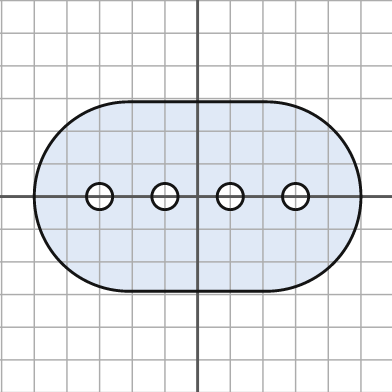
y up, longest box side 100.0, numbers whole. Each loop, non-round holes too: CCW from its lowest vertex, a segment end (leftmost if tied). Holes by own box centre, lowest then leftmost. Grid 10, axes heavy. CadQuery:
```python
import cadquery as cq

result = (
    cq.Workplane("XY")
    .moveTo(-21.0, -29.0)
    .lineTo(21.0, -29.0)
    .threePointArc((50.0, 0.0), (21.0, 29.0))
    .lineTo(-21.0, 29.0)
    .threePointArc((-50.0, 0.0), (-21.0, -29.0))
    .close()
    .moveTo(-30.0, 0.0)
    .circle(4.0)
    .moveTo(-10.0, 0.0)
    .circle(4.0)
    .moveTo(10.0, 0.0)
    .circle(4.0)
    .moveTo(30.0, 0.0)
    .circle(4.0)
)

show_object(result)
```